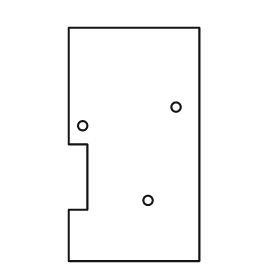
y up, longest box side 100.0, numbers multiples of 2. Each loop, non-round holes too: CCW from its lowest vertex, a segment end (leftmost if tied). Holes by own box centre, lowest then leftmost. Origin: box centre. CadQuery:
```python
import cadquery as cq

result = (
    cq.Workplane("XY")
    .moveTo(-28.0, -50.0)
    .lineTo(28.0, -50.0)
    .lineTo(28.0, 50.0)
    .lineTo(-28.0, 50.0)
    .lineTo(-28.0, 0.0)
    .lineTo(-20.0, 0.0)
    .lineTo(-20.0, -28.0)
    .lineTo(-28.0, -28.0)
    .close()
    .moveTo(6.0, -24.0)
    .circle(2.0)
    .moveTo(-22.0, 8.0)
    .circle(2.0)
    .moveTo(18.0, 16.0)
    .circle(2.0)
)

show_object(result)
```